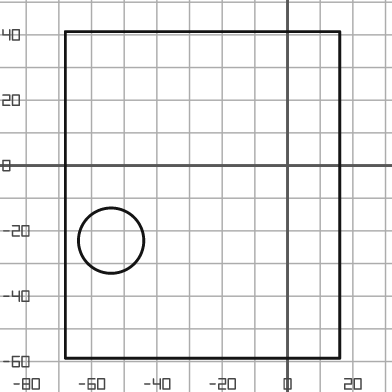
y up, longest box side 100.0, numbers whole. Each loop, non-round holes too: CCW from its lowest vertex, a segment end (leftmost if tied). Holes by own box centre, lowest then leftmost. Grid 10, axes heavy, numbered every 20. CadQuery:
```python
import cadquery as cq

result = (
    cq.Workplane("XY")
    .moveTo(-68.0, -59.0)
    .lineTo(16.0, -59.0)
    .lineTo(16.0, 41.0)
    .lineTo(-68.0, 41.0)
    .close()
    .moveTo(-54.0, -23.0)
    .circle(10.0)
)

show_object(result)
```